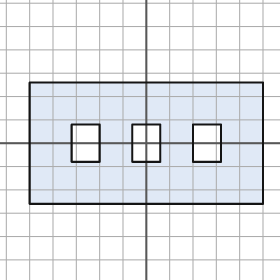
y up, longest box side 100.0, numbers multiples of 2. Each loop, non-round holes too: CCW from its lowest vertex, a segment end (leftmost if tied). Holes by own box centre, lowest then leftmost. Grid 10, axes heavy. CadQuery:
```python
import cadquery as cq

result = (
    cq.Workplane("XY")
    .moveTo(-50.0, -26.0)
    .lineTo(50.0, -26.0)
    .lineTo(50.0, 26.0)
    .lineTo(-50.0, 26.0)
    .close()
    .moveTo(-32.0, -8.0)
    .lineTo(-20.0, -8.0)
    .lineTo(-20.0, 8.0)
    .lineTo(-32.0, 8.0)
    .close()
    .moveTo(-6.0, -8.0)
    .lineTo(6.0, -8.0)
    .lineTo(6.0, 8.0)
    .lineTo(-6.0, 8.0)
    .close()
    .moveTo(20.0, -8.0)
    .lineTo(32.0, -8.0)
    .lineTo(32.0, 8.0)
    .lineTo(20.0, 8.0)
    .close()
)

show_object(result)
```